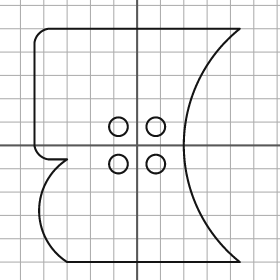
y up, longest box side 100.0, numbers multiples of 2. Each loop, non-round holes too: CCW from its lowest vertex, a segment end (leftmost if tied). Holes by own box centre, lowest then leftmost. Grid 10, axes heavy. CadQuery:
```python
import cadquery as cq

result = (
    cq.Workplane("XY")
    .moveTo(-30.0, -50.0)
    .lineTo(44.0, -50.0)
    .threePointArc((20.0, 0.0), (44.0, 50.0))
    .lineTo(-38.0, 50.0)
    .threePointArc((-42.0, 48.0), (-44.0, 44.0))
    .lineTo(-44.0, 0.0)
    .threePointArc((-42.0, -4.0), (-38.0, -6.0))
    .lineTo(-30.0, -6.0)
    .threePointArc((-42.0, -28.0), (-30.0, -50.0))
    .close()
    .moveTo(-8.0, -8.0)
    .circle(4.0)
    .moveTo(8.0, -8.0)
    .circle(4.0)
    .moveTo(-8.0, 8.0)
    .circle(4.0)
    .moveTo(8.0, 8.0)
    .circle(4.0)
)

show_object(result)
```